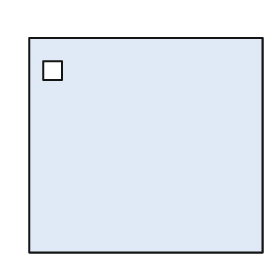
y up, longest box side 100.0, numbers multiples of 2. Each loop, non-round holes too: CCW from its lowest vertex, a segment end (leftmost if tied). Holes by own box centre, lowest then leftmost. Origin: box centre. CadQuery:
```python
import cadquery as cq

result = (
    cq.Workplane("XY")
    .moveTo(-50.0, -46.0)
    .lineTo(50.0, -46.0)
    .lineTo(50.0, 46.0)
    .lineTo(-50.0, 46.0)
    .close()
    .moveTo(-44.0, 28.0)
    .lineTo(-36.0, 28.0)
    .lineTo(-36.0, 36.0)
    .lineTo(-44.0, 36.0)
    .close()
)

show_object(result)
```